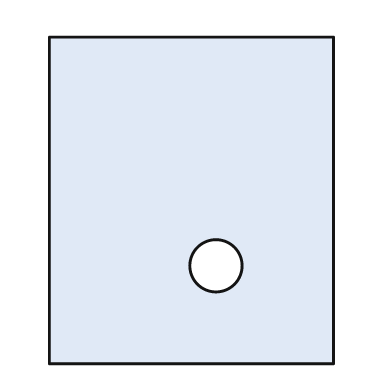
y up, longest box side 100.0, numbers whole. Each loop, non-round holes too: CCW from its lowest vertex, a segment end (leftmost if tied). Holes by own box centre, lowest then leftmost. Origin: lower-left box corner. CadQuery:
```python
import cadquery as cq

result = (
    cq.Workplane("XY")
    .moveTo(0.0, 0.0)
    .lineTo(87.0, 0.0)
    .lineTo(87.0, 100.0)
    .lineTo(0.0, 100.0)
    .close()
    .moveTo(51.0, 30.0)
    .circle(8.0)
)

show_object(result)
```